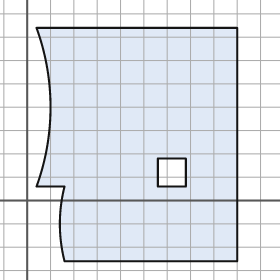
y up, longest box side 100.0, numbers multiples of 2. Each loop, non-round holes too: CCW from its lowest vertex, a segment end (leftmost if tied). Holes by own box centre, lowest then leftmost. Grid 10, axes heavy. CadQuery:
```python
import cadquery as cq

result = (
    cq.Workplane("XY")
    .moveTo(16.0, -26.0)
    .lineTo(90.0, -26.0)
    .lineTo(90.0, 74.0)
    .lineTo(4.0, 74.0)
    .threePointArc((10.0, 40.0), (4.0, 6.0))
    .lineTo(16.0, 6.0)
    .threePointArc((14.0, -10.0), (16.0, -26.0))
    .close()
    .moveTo(56.0, 6.0)
    .lineTo(68.0, 6.0)
    .lineTo(68.0, 18.0)
    .lineTo(56.0, 18.0)
    .close()
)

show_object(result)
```